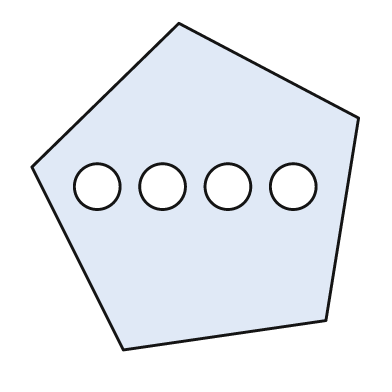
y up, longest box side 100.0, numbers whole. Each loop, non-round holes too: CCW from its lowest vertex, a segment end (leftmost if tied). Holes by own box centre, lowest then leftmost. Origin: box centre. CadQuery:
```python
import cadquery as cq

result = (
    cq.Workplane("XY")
    .moveTo(-22.0, -50.0)
    .lineTo(40.0, -41.0)
    .lineTo(50.0, 21.0)
    .lineTo(-5.0, 50.0)
    .lineTo(-50.0, 6.0)
    .close()
    .moveTo(-30.0, 0.0)
    .circle(7.0)
    .moveTo(-10.0, 0.0)
    .circle(7.0)
    .moveTo(10.0, 0.0)
    .circle(7.0)
    .moveTo(30.0, 0.0)
    .circle(7.0)
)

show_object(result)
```